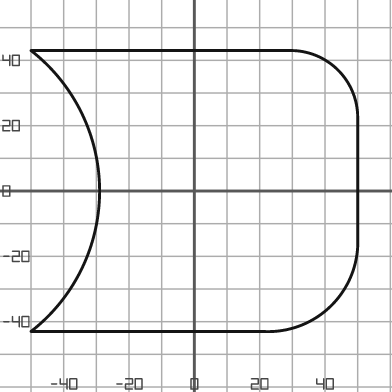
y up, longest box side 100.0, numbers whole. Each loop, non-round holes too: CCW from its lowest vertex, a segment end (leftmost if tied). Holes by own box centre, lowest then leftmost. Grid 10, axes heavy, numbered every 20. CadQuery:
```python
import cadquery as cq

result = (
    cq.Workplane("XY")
    .moveTo(-50.0, -43.0)
    .lineTo(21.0, -43.0)
    .threePointArc((42.0, -35.0), (50.0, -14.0))
    .lineTo(50.0, 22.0)
    .threePointArc((44.0, 37.0), (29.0, 43.0))
    .lineTo(-50.0, 43.0)
    .threePointArc((-29.0, 0.0), (-50.0, -43.0))
    .close()
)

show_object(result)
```